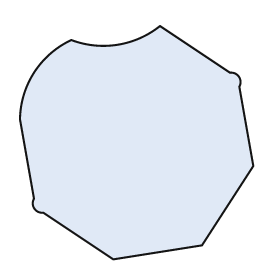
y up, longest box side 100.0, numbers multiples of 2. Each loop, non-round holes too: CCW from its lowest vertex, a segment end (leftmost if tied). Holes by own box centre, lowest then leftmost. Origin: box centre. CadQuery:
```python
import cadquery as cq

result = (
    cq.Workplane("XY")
    .moveTo(-10.0, -50.0)
    .lineTo(28.0, -44.0)
    .lineTo(50.0, -10.0)
    .lineTo(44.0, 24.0)
    .threePointArc((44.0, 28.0), (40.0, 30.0))
    .lineTo(10.0, 50.0)
    .threePointArc((-8.0, 42.0), (-28.0, 44.0))
    .threePointArc((-44.0, 30.0), (-50.0, 10.0))
    .lineTo(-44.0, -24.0)
    .threePointArc((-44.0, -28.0), (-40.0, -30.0))
    .close()
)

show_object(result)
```